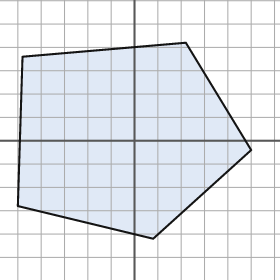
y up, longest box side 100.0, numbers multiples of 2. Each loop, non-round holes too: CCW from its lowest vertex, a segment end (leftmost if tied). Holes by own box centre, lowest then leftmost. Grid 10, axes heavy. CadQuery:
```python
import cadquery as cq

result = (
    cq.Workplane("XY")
    .moveTo(8.0, -42.0)
    .lineTo(50.0, -4.0)
    .lineTo(22.0, 42.0)
    .lineTo(-48.0, 36.0)
    .lineTo(-50.0, -28.0)
    .close()
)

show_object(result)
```